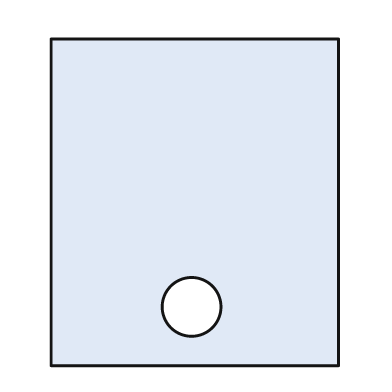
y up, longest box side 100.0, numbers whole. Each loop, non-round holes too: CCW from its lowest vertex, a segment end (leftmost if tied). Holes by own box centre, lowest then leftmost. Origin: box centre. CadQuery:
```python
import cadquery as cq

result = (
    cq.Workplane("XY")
    .moveTo(-44.0, -50.0)
    .lineTo(44.0, -50.0)
    .lineTo(44.0, 50.0)
    .lineTo(-44.0, 50.0)
    .close()
    .moveTo(-1.0, -32.0)
    .circle(9.0)
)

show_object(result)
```